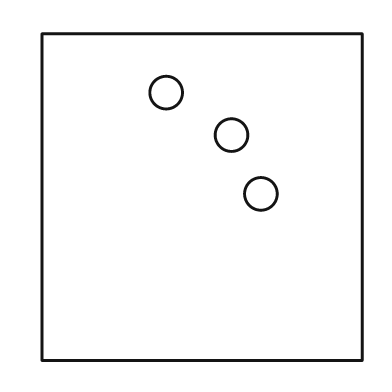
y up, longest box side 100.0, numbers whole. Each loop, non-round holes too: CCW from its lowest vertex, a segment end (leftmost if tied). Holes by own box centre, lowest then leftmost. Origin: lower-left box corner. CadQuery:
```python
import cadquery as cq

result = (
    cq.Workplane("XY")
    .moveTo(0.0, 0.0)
    .lineTo(98.0, 0.0)
    .lineTo(98.0, 100.0)
    .lineTo(0.0, 100.0)
    .close()
    .moveTo(67.0, 51.0)
    .circle(5.0)
    .moveTo(58.0, 69.0)
    .circle(5.0)
    .moveTo(38.0, 82.0)
    .circle(5.0)
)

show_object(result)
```